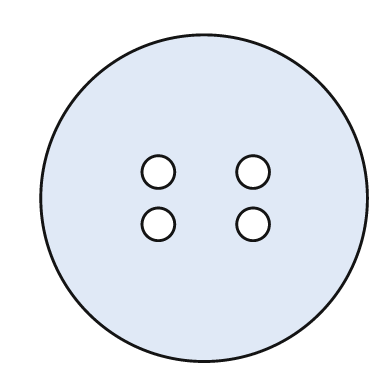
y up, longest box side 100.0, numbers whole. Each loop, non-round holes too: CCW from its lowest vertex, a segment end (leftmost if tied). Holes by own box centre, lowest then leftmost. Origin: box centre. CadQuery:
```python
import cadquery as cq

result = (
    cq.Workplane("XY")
    .moveTo(0.0, 0.0)
    .circle(50.0)
    .moveTo(-14.0, -8.0)
    .circle(5.0)
    .moveTo(15.0, -8.0)
    .circle(5.0)
    .moveTo(-14.0, 8.0)
    .circle(5.0)
    .moveTo(15.0, 8.0)
    .circle(5.0)
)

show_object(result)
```